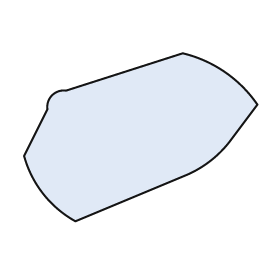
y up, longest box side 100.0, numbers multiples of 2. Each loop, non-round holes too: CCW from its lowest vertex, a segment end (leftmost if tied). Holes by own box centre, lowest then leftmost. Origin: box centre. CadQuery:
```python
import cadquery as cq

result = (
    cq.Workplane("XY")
    .moveTo(-28.0, -36.0)
    .lineTo(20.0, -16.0)
    .threePointArc((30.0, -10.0), (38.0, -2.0))
    .lineTo(50.0, 14.0)
    .threePointArc((36.0, 28.0), (18.0, 36.0))
    .lineTo(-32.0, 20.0)
    .threePointArc((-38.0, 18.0), (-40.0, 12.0))
    .lineTo(-50.0, -8.0)
    .threePointArc((-42.0, -24.0), (-28.0, -36.0))
    .close()
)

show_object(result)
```